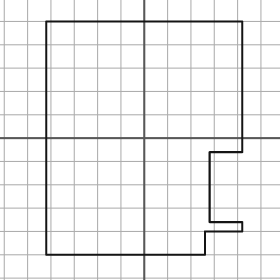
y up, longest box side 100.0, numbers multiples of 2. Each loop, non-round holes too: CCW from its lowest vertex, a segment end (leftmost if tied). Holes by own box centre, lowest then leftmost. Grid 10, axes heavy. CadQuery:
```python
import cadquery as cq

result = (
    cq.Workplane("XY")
    .moveTo(-42.0, -50.0)
    .lineTo(26.0, -50.0)
    .lineTo(26.0, -40.0)
    .lineTo(42.0, -40.0)
    .lineTo(42.0, -36.0)
    .lineTo(28.0, -36.0)
    .lineTo(28.0, -6.0)
    .lineTo(42.0, -6.0)
    .lineTo(42.0, 50.0)
    .lineTo(-42.0, 50.0)
    .close()
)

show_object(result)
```